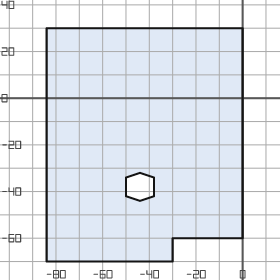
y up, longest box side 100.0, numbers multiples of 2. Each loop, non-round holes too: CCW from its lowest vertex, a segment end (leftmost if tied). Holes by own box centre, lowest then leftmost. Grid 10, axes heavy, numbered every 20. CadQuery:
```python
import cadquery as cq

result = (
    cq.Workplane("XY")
    .moveTo(-84.0, -70.0)
    .lineTo(-30.0, -70.0)
    .lineTo(-30.0, -60.0)
    .lineTo(0.0, -60.0)
    .lineTo(0.0, 30.0)
    .lineTo(-84.0, 30.0)
    .close()
    .moveTo(-44.0, -44.0)
    .lineTo(-38.0, -42.0)
    .lineTo(-38.0, -34.0)
    .lineTo(-44.0, -32.0)
    .lineTo(-50.0, -34.0)
    .lineTo(-50.0, -42.0)
    .close()
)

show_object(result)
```